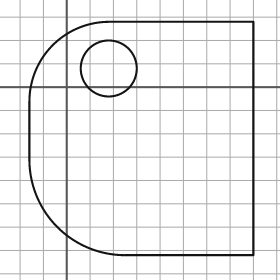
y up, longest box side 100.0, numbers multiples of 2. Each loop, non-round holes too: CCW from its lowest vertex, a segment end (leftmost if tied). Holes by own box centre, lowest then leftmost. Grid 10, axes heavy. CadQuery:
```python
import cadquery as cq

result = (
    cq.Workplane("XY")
    .moveTo(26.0, -72.0)
    .lineTo(80.0, -72.0)
    .lineTo(80.0, 28.0)
    .lineTo(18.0, 28.0)
    .threePointArc((-6.0, 18.0), (-16.0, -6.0))
    .lineTo(-16.0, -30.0)
    .threePointArc((-4.0, -60.0), (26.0, -72.0))
    .close()
    .moveTo(18.0, 8.0)
    .circle(12.0)
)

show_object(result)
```